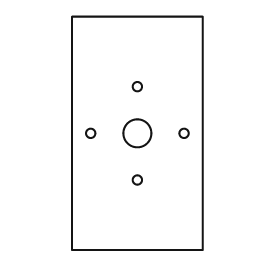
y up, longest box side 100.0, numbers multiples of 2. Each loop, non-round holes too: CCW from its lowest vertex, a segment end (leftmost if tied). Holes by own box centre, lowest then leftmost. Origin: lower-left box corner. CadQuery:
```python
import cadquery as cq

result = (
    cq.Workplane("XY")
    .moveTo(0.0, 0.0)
    .lineTo(56.0, 0.0)
    .lineTo(56.0, 100.0)
    .lineTo(0.0, 100.0)
    .close()
    .moveTo(28.0, 30.0)
    .circle(2.0)
    .moveTo(8.0, 50.0)
    .circle(2.0)
    .moveTo(28.0, 50.0)
    .circle(6.0)
    .moveTo(48.0, 50.0)
    .circle(2.0)
    .moveTo(28.0, 70.0)
    .circle(2.0)
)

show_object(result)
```